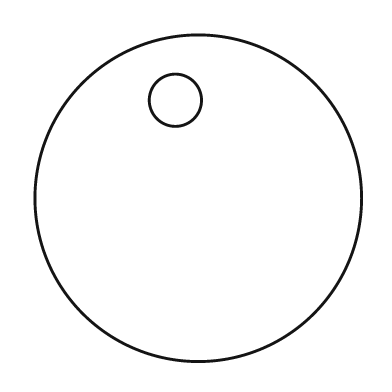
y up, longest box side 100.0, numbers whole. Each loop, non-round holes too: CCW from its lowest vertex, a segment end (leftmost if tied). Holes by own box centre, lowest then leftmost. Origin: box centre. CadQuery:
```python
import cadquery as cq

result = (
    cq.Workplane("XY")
    .moveTo(0.0, 0.0)
    .circle(50.0)
    .moveTo(-7.0, 30.0)
    .circle(8.0)
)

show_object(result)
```